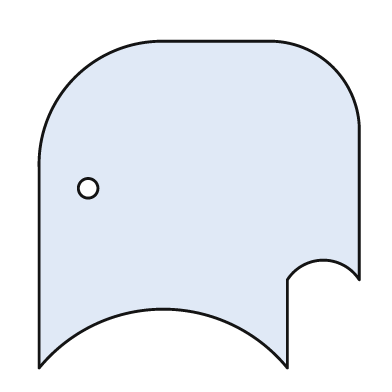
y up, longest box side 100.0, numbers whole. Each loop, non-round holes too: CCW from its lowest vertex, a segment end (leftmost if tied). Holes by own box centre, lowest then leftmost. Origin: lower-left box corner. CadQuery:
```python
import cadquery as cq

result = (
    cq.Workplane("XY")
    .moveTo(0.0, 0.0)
    .threePointArc((38.0, 18.0), (76.0, 0.0))
    .lineTo(76.0, 27.0)
    .threePointArc((87.0, 33.0), (98.0, 27.0))
    .lineTo(98.0, 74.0)
    .threePointArc((90.0, 92.0), (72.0, 100.0))
    .lineTo(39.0, 100.0)
    .threePointArc((11.0, 89.0), (0.0, 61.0))
    .close()
    .moveTo(15.0, 55.0)
    .circle(3.0)
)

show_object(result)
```